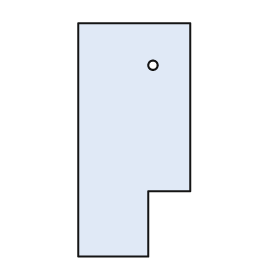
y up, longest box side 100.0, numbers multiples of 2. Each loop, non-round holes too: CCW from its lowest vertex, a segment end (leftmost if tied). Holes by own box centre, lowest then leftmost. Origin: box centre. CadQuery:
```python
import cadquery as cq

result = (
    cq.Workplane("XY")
    .moveTo(-24.0, -50.0)
    .lineTo(6.0, -50.0)
    .lineTo(6.0, -22.0)
    .lineTo(24.0, -22.0)
    .lineTo(24.0, 50.0)
    .lineTo(-24.0, 50.0)
    .close()
    .moveTo(8.0, 32.0)
    .circle(2.0)
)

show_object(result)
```